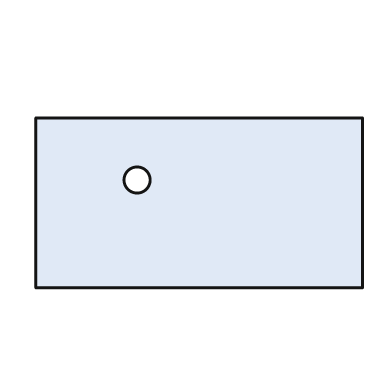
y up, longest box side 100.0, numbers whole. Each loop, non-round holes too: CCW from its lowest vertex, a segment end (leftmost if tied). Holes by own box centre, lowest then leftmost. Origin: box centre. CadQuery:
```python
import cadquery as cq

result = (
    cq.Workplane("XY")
    .moveTo(-50.0, -26.0)
    .lineTo(50.0, -26.0)
    .lineTo(50.0, 26.0)
    .lineTo(-50.0, 26.0)
    .close()
    .moveTo(-19.0, 7.0)
    .circle(4.0)
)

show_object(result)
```